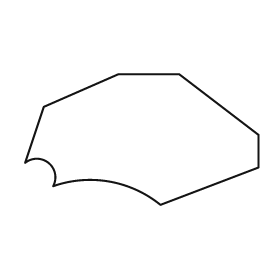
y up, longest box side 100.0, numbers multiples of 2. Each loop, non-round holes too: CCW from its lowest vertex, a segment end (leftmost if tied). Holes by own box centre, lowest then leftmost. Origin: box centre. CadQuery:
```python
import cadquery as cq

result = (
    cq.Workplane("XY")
    .moveTo(8.0, -28.0)
    .lineTo(50.0, -12.0)
    .lineTo(50.0, 2.0)
    .lineTo(16.0, 28.0)
    .lineTo(-10.0, 28.0)
    .lineTo(-42.0, 14.0)
    .lineTo(-50.0, -10.0)
    .threePointArc((-40.0, -10.0), (-38.0, -20.0))
    .threePointArc((-14.0, -18.0), (8.0, -28.0))
    .close()
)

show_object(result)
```